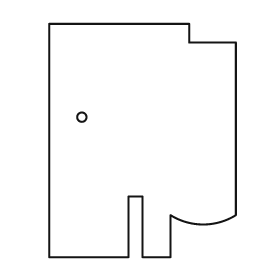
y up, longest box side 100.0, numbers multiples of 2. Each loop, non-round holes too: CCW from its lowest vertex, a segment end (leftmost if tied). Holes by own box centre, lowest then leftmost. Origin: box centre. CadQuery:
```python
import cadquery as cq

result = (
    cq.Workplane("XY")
    .moveTo(-40.0, -50.0)
    .lineTo(-6.0, -50.0)
    .lineTo(-6.0, -24.0)
    .lineTo(0.0, -24.0)
    .lineTo(0.0, -50.0)
    .lineTo(12.0, -50.0)
    .lineTo(12.0, -32.0)
    .threePointArc((26.0, -36.0), (40.0, -32.0))
    .lineTo(40.0, 42.0)
    .lineTo(20.0, 42.0)
    .lineTo(20.0, 50.0)
    .lineTo(-40.0, 50.0)
    .close()
    .moveTo(-26.0, 10.0)
    .circle(2.0)
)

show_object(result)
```